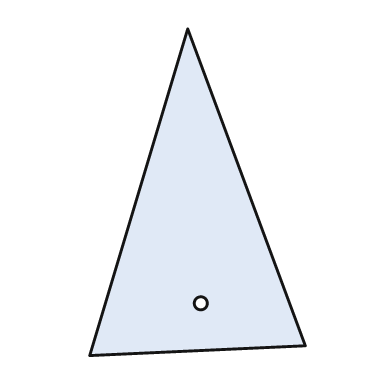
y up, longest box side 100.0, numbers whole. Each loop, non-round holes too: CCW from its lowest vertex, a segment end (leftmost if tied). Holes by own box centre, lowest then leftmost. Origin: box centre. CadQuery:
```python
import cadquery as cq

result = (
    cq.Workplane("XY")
    .moveTo(-33.0, -50.0)
    .lineTo(33.0, -47.0)
    .lineTo(-3.0, 50.0)
    .close()
    .moveTo(1.0, -34.0)
    .circle(2.0)
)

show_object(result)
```